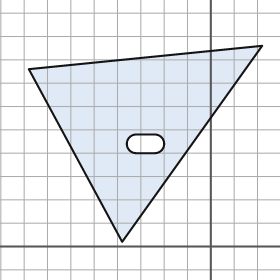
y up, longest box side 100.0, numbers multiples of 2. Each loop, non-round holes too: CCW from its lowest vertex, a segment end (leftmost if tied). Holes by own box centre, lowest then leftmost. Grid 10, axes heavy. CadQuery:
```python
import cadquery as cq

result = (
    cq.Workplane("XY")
    .moveTo(-38.0, 2.0)
    .lineTo(22.0, 86.0)
    .lineTo(-78.0, 76.0)
    .close()
    .moveTo(-32.0, 40.0)
    .lineTo(-24.0, 40.0)
    .threePointArc((-20.0, 44.0), (-24.0, 48.0))
    .lineTo(-32.0, 48.0)
    .threePointArc((-36.0, 44.0), (-32.0, 40.0))
    .close()
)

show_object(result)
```